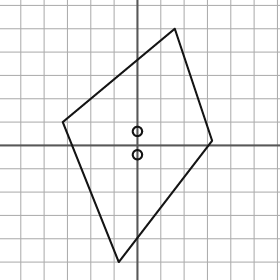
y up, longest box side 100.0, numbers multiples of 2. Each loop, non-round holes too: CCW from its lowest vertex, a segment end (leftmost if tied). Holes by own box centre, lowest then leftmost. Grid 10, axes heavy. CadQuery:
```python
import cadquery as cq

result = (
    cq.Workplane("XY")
    .moveTo(-8.0, -50.0)
    .lineTo(32.0, 2.0)
    .lineTo(16.0, 50.0)
    .lineTo(-32.0, 10.0)
    .close()
    .moveTo(0.0, -4.0)
    .circle(2.0)
    .moveTo(0.0, 6.0)
    .circle(2.0)
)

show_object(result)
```